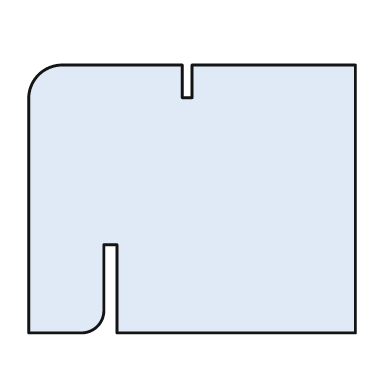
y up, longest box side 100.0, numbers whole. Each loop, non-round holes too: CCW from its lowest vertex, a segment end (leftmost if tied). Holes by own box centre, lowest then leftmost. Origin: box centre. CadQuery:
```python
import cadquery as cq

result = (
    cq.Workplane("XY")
    .moveTo(-50.0, -41.0)
    .lineTo(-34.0, -41.0)
    .threePointArc((-29.0, -39.0), (-27.0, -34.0))
    .lineTo(-27.0, -14.0)
    .lineTo(-23.0, -14.0)
    .lineTo(-23.0, -41.0)
    .lineTo(50.0, -41.0)
    .lineTo(50.0, 41.0)
    .lineTo(0.0, 41.0)
    .lineTo(0.0, 31.0)
    .lineTo(-3.0, 31.0)
    .lineTo(-3.0, 41.0)
    .lineTo(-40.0, 41.0)
    .threePointArc((-47.0, 38.0), (-50.0, 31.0))
    .close()
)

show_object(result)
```